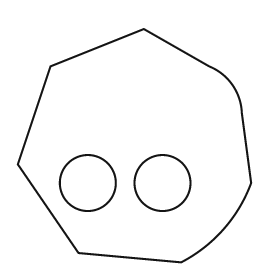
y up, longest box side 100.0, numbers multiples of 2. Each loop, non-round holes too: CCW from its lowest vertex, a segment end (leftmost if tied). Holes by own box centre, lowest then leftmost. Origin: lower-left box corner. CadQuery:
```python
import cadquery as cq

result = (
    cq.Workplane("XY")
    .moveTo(70.0, 0.0)
    .threePointArc((88.0, 14.0), (100.0, 34.0))
    .lineTo(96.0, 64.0)
    .threePointArc((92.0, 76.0), (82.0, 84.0))
    .lineTo(54.0, 100.0)
    .lineTo(14.0, 84.0)
    .lineTo(0.0, 42.0)
    .lineTo(26.0, 4.0)
    .close()
    .moveTo(30.0, 34.0)
    .circle(12.0)
    .moveTo(62.0, 34.0)
    .circle(12.0)
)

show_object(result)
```